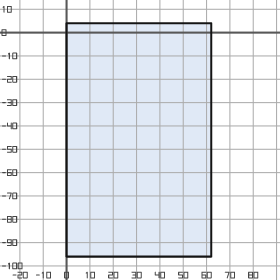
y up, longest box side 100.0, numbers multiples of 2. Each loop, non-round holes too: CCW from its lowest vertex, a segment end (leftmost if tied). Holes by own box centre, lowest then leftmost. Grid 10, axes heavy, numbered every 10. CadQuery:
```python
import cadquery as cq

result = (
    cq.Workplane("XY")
    .moveTo(0.0, -96.0)
    .lineTo(62.0, -96.0)
    .lineTo(62.0, 4.0)
    .lineTo(0.0, 4.0)
    .close()
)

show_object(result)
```